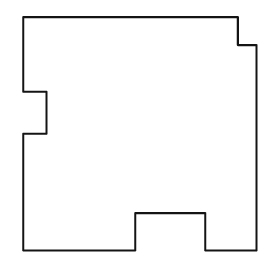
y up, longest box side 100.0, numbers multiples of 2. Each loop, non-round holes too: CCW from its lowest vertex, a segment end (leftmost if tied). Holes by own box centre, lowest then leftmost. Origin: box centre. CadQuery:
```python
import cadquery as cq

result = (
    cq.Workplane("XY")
    .moveTo(-50.0, -50.0)
    .lineTo(-2.0, -50.0)
    .lineTo(-2.0, -34.0)
    .lineTo(28.0, -34.0)
    .lineTo(28.0, -50.0)
    .lineTo(50.0, -50.0)
    .lineTo(50.0, 38.0)
    .lineTo(42.0, 38.0)
    .lineTo(42.0, 50.0)
    .lineTo(-50.0, 50.0)
    .lineTo(-50.0, 18.0)
    .lineTo(-40.0, 18.0)
    .lineTo(-40.0, 0.0)
    .lineTo(-50.0, 0.0)
    .close()
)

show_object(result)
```